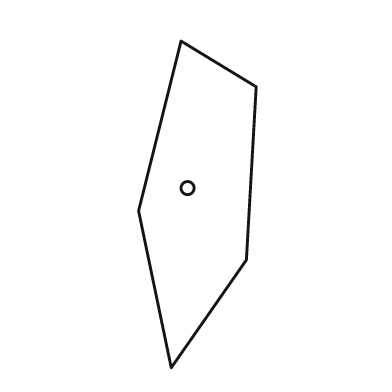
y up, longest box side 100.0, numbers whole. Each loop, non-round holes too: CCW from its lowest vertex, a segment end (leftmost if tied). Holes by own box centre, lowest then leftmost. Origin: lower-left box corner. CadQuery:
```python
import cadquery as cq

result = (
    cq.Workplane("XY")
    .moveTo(10.0, 0.0)
    .lineTo(33.0, 33.0)
    .lineTo(36.0, 86.0)
    .lineTo(13.0, 100.0)
    .lineTo(0.0, 48.0)
    .close()
    .moveTo(15.0, 55.0)
    .circle(2.0)
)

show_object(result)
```